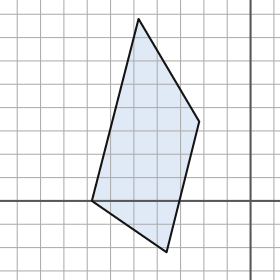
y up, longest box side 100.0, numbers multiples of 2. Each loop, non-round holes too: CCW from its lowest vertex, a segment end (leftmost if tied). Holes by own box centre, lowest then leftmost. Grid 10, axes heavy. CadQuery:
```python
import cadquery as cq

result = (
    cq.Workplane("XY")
    .moveTo(-36.0, -22.0)
    .lineTo(-22.0, 34.0)
    .lineTo(-48.0, 78.0)
    .lineTo(-68.0, 0.0)
    .close()
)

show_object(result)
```